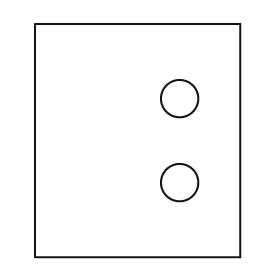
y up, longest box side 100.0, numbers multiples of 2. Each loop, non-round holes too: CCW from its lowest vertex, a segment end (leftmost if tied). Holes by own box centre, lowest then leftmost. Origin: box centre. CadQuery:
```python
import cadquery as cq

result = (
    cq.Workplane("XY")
    .moveTo(-44.0, -50.0)
    .lineTo(44.0, -50.0)
    .lineTo(44.0, 50.0)
    .lineTo(-44.0, 50.0)
    .close()
    .moveTo(18.0, -18.0)
    .circle(8.0)
    .moveTo(18.0, 18.0)
    .circle(8.0)
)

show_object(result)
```